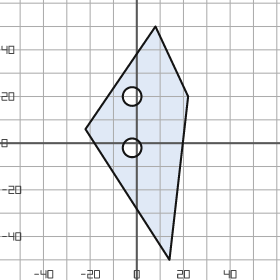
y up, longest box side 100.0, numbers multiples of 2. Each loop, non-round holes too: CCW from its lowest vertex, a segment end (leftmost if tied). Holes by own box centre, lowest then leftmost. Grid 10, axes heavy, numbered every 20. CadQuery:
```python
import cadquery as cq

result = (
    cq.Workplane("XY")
    .moveTo(14.0, -50.0)
    .lineTo(22.0, 20.0)
    .lineTo(8.0, 50.0)
    .lineTo(-22.0, 6.0)
    .close()
    .moveTo(-2.0, -2.0)
    .circle(4.0)
    .moveTo(-2.0, 20.0)
    .circle(4.0)
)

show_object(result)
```